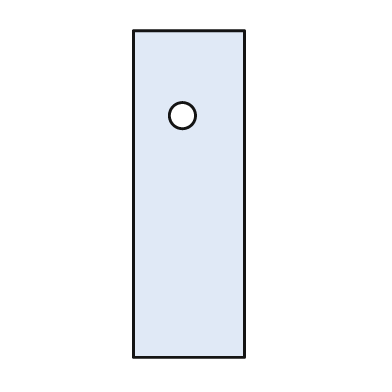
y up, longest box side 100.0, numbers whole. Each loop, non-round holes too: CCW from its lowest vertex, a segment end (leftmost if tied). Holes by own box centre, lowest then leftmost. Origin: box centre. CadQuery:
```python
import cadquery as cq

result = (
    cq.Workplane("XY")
    .moveTo(-17.0, -50.0)
    .lineTo(17.0, -50.0)
    .lineTo(17.0, 50.0)
    .lineTo(-17.0, 50.0)
    .close()
    .moveTo(-2.0, 24.0)
    .circle(4.0)
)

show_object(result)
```